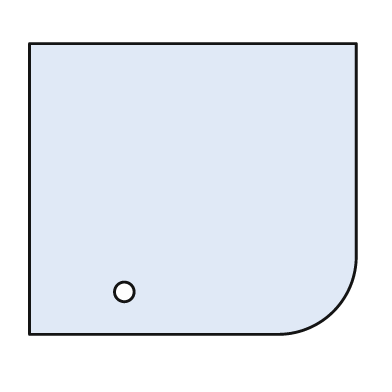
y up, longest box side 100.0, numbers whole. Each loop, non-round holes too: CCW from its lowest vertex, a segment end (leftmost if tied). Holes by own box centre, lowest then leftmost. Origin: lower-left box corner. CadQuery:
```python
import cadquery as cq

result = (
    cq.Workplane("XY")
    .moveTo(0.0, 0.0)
    .lineTo(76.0, 0.0)
    .threePointArc((93.0, 7.0), (100.0, 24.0))
    .lineTo(100.0, 89.0)
    .lineTo(0.0, 89.0)
    .close()
    .moveTo(29.0, 13.0)
    .circle(3.0)
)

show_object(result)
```